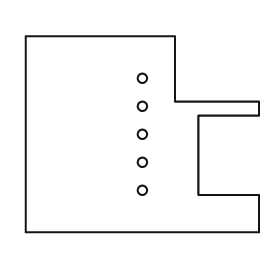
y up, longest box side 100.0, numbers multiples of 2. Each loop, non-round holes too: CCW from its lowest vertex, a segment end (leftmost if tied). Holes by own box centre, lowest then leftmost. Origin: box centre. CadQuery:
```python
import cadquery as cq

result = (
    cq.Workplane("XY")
    .moveTo(-50.0, -42.0)
    .lineTo(50.0, -42.0)
    .lineTo(50.0, -26.0)
    .lineTo(24.0, -26.0)
    .lineTo(24.0, 8.0)
    .lineTo(50.0, 8.0)
    .lineTo(50.0, 14.0)
    .lineTo(14.0, 14.0)
    .lineTo(14.0, 42.0)
    .lineTo(-50.0, 42.0)
    .close()
    .moveTo(0.0, -24.0)
    .circle(2.0)
    .moveTo(0.0, -12.0)
    .circle(2.0)
    .moveTo(0.0, 0.0)
    .circle(2.0)
    .moveTo(0.0, 12.0)
    .circle(2.0)
    .moveTo(0.0, 24.0)
    .circle(2.0)
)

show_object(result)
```